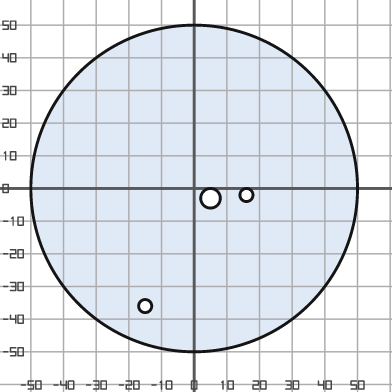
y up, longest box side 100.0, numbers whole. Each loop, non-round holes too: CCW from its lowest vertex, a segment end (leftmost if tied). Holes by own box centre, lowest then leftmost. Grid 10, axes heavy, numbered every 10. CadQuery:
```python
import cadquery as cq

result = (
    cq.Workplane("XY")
    .moveTo(0.0, 0.0)
    .circle(50.0)
    .moveTo(-15.0, -36.0)
    .circle(2.0)
    .moveTo(5.0, -3.0)
    .circle(3.0)
    .moveTo(16.0, -2.0)
    .circle(2.0)
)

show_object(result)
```